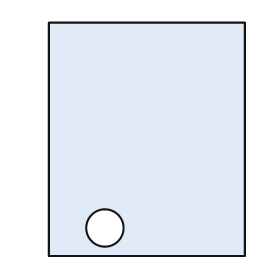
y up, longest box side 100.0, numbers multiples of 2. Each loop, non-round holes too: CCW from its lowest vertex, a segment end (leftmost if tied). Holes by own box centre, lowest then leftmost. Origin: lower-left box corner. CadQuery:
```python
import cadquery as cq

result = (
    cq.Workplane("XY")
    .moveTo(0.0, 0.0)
    .lineTo(84.0, 0.0)
    .lineTo(84.0, 100.0)
    .lineTo(0.0, 100.0)
    .close()
    .moveTo(24.0, 12.0)
    .circle(8.0)
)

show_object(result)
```